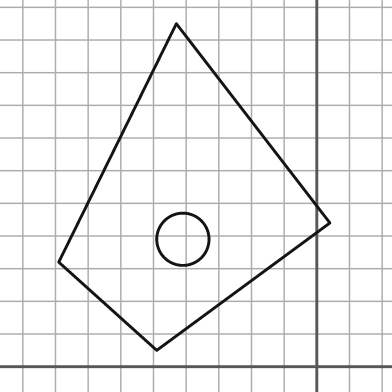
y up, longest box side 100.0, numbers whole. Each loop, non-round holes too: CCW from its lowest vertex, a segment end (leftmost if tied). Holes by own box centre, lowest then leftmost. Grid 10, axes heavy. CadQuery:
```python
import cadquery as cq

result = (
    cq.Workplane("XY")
    .moveTo(-49.0, 5.0)
    .lineTo(4.0, 44.0)
    .lineTo(-43.0, 105.0)
    .lineTo(-79.0, 32.0)
    .close()
    .moveTo(-41.0, 39.0)
    .circle(8.0)
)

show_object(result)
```